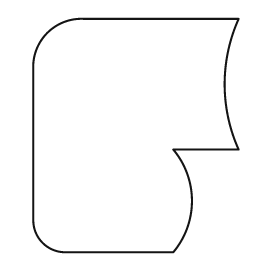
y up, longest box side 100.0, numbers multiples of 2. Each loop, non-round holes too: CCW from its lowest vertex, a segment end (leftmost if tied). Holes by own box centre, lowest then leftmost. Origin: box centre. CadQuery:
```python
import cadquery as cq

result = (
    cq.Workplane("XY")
    .moveTo(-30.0, -50.0)
    .lineTo(16.0, -50.0)
    .threePointArc((24.0, -28.0), (16.0, -6.0))
    .lineTo(44.0, -6.0)
    .threePointArc((38.0, 22.0), (44.0, 50.0))
    .lineTo(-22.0, 50.0)
    .threePointArc((-38.0, 44.0), (-44.0, 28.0))
    .lineTo(-44.0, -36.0)
    .threePointArc((-40.0, -46.0), (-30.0, -50.0))
    .close()
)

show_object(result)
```